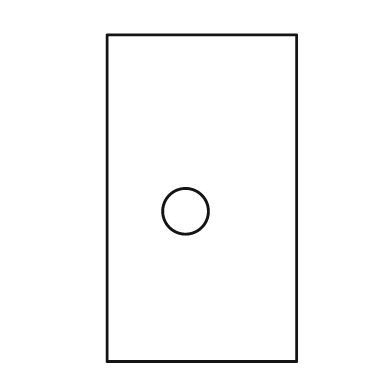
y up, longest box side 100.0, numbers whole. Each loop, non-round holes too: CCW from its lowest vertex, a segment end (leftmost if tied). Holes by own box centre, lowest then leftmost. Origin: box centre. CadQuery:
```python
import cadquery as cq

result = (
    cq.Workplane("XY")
    .moveTo(-29.0, -50.0)
    .lineTo(29.0, -50.0)
    .lineTo(29.0, 50.0)
    .lineTo(-29.0, 50.0)
    .close()
    .moveTo(-5.0, -4.0)
    .circle(7.0)
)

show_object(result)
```